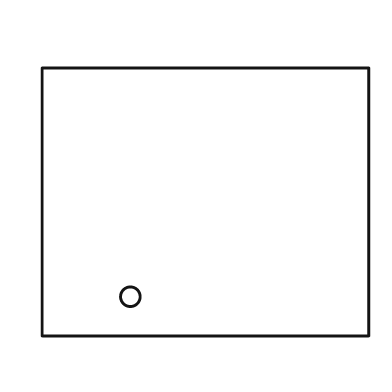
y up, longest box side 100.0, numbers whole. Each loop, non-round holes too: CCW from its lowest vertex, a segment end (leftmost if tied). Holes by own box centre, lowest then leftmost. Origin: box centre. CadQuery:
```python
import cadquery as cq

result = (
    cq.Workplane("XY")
    .moveTo(-50.0, -41.0)
    .lineTo(50.0, -41.0)
    .lineTo(50.0, 41.0)
    .lineTo(-50.0, 41.0)
    .close()
    .moveTo(-23.0, -29.0)
    .circle(3.0)
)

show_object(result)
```